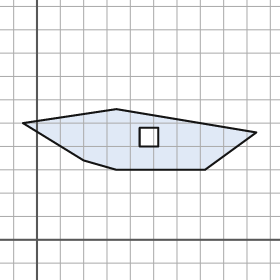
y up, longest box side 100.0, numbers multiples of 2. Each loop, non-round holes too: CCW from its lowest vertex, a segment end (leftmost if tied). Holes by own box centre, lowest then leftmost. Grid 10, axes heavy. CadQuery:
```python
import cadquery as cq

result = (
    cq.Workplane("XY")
    .moveTo(34.0, 30.0)
    .lineTo(72.0, 30.0)
    .lineTo(94.0, 46.0)
    .lineTo(34.0, 56.0)
    .lineTo(-6.0, 50.0)
    .lineTo(20.0, 34.0)
    .close()
    .moveTo(44.0, 40.0)
    .lineTo(52.0, 40.0)
    .lineTo(52.0, 48.0)
    .lineTo(44.0, 48.0)
    .close()
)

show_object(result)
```